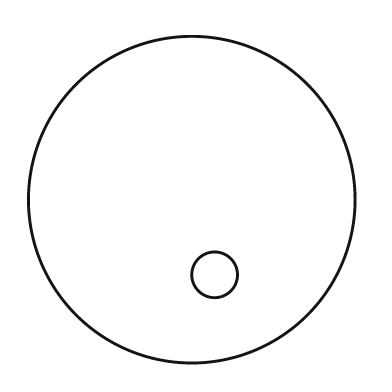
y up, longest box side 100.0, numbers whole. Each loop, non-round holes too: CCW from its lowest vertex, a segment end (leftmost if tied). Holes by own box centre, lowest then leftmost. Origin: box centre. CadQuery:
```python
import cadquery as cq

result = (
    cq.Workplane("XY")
    .moveTo(0.0, 0.0)
    .circle(50.0)
    .moveTo(7.0, -23.0)
    .circle(7.0)
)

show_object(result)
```